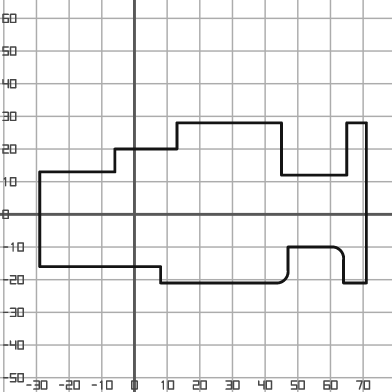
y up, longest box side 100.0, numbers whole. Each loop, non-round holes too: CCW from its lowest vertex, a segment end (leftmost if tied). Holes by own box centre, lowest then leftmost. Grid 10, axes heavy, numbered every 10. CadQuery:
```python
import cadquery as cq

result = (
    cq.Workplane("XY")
    .moveTo(8.0, -21.0)
    .lineTo(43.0, -21.0)
    .threePointArc((46.0, -20.0), (47.0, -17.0))
    .lineTo(47.0, -10.0)
    .lineTo(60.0, -10.0)
    .threePointArc((63.0, -11.0), (64.0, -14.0))
    .lineTo(64.0, -21.0)
    .lineTo(71.0, -21.0)
    .lineTo(71.0, 28.0)
    .lineTo(65.0, 28.0)
    .lineTo(65.0, 12.0)
    .lineTo(45.0, 12.0)
    .lineTo(45.0, 28.0)
    .lineTo(13.0, 28.0)
    .lineTo(13.0, 20.0)
    .lineTo(-6.0, 20.0)
    .lineTo(-6.0, 13.0)
    .lineTo(-29.0, 13.0)
    .lineTo(-29.0, -16.0)
    .lineTo(8.0, -16.0)
    .close()
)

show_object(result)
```